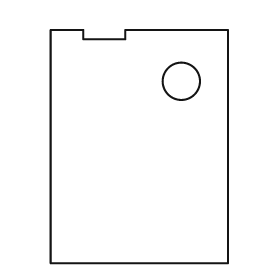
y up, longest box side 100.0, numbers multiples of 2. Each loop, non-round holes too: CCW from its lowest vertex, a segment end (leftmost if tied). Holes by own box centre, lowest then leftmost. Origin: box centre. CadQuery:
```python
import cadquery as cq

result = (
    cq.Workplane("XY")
    .moveTo(-38.0, -50.0)
    .lineTo(38.0, -50.0)
    .lineTo(38.0, 50.0)
    .lineTo(-6.0, 50.0)
    .lineTo(-6.0, 46.0)
    .lineTo(-24.0, 46.0)
    .lineTo(-24.0, 50.0)
    .lineTo(-38.0, 50.0)
    .close()
    .moveTo(18.0, 28.0)
    .circle(8.0)
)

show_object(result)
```